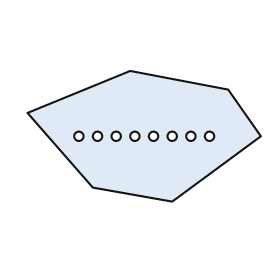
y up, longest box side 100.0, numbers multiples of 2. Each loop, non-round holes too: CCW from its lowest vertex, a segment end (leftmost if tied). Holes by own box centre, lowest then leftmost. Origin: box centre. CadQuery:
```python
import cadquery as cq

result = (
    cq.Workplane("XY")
    .moveTo(12.0, -28.0)
    .lineTo(50.0, 0.0)
    .lineTo(36.0, 20.0)
    .lineTo(-6.0, 28.0)
    .lineTo(-50.0, 10.0)
    .lineTo(-22.0, -22.0)
    .close()
    .moveTo(-28.0, 0.0)
    .circle(2.0)
    .moveTo(-20.0, 0.0)
    .circle(2.0)
    .moveTo(-12.0, 0.0)
    .circle(2.0)
    .moveTo(-4.0, 0.0)
    .circle(2.0)
    .moveTo(4.0, 0.0)
    .circle(2.0)
    .moveTo(12.0, 0.0)
    .circle(2.0)
    .moveTo(20.0, 0.0)
    .circle(2.0)
    .moveTo(28.0, 0.0)
    .circle(2.0)
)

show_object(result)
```